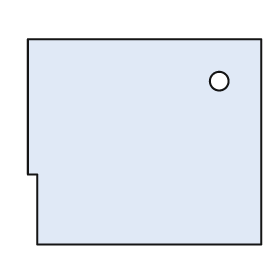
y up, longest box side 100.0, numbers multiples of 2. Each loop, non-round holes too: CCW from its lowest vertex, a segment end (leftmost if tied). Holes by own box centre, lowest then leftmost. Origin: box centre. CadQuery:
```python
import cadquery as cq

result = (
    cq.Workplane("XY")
    .moveTo(-46.0, -44.0)
    .lineTo(50.0, -44.0)
    .lineTo(50.0, 44.0)
    .lineTo(-50.0, 44.0)
    .lineTo(-50.0, -14.0)
    .lineTo(-46.0, -14.0)
    .close()
    .moveTo(32.0, 26.0)
    .circle(4.0)
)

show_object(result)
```